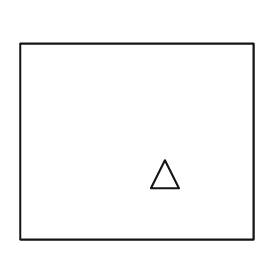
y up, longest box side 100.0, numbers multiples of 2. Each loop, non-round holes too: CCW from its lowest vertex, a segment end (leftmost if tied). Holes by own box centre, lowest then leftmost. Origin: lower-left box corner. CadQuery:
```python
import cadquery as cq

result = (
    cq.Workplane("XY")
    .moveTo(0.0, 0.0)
    .lineTo(100.0, 0.0)
    .lineTo(100.0, 84.0)
    .lineTo(0.0, 84.0)
    .close()
    .moveTo(56.0, 22.0)
    .lineTo(68.0, 22.0)
    .lineTo(62.0, 34.0)
    .close()
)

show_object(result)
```